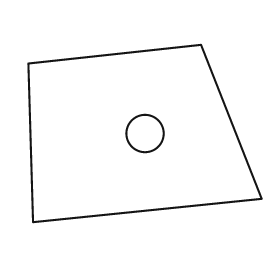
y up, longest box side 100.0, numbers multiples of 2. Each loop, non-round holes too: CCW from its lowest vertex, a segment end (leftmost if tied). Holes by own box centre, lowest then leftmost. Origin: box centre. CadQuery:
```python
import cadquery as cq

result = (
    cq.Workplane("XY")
    .moveTo(-48.0, -38.0)
    .lineTo(50.0, -28.0)
    .lineTo(24.0, 38.0)
    .lineTo(-50.0, 30.0)
    .close()
    .moveTo(0.0, 0.0)
    .circle(8.0)
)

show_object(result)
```